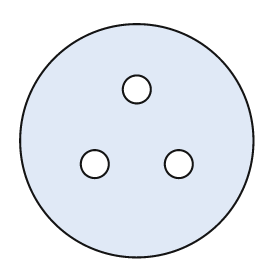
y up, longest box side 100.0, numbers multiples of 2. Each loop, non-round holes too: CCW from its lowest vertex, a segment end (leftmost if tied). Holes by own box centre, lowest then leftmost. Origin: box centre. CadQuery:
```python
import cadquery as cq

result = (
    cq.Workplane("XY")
    .moveTo(0.0, 0.0)
    .circle(50.0)
    .moveTo(-18.0, -10.0)
    .circle(6.0)
    .moveTo(18.0, -10.0)
    .circle(6.0)
    .moveTo(0.0, 22.0)
    .circle(6.0)
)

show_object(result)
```